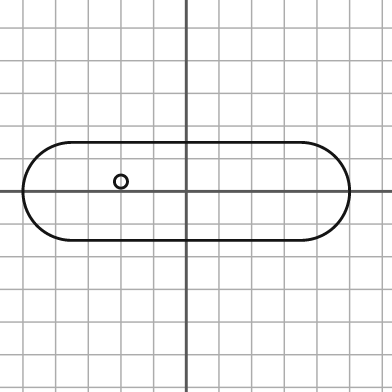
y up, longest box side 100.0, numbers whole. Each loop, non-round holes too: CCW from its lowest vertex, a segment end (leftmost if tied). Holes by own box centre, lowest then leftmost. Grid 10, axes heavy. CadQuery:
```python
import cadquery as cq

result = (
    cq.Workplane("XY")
    .moveTo(-35.0, -15.0)
    .lineTo(35.0, -15.0)
    .threePointArc((50.0, 0.0), (35.0, 15.0))
    .lineTo(-35.0, 15.0)
    .threePointArc((-50.0, 0.0), (-35.0, -15.0))
    .close()
    .moveTo(-20.0, 3.0)
    .circle(2.0)
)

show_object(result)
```